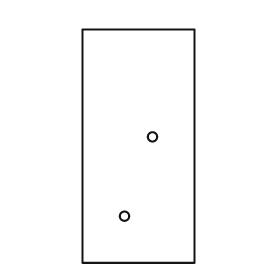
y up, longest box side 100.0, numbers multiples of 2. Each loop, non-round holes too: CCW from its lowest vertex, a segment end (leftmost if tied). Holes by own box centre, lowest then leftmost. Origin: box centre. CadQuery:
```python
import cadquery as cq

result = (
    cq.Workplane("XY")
    .moveTo(-24.0, -50.0)
    .lineTo(24.0, -50.0)
    .lineTo(24.0, 50.0)
    .lineTo(-24.0, 50.0)
    .close()
    .moveTo(-6.0, -30.0)
    .circle(2.0)
    .moveTo(6.0, 4.0)
    .circle(2.0)
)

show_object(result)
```